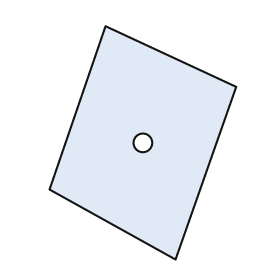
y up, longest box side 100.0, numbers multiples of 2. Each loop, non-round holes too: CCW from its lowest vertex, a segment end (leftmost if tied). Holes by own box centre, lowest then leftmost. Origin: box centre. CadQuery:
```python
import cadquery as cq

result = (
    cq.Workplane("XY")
    .moveTo(14.0, -50.0)
    .lineTo(40.0, 24.0)
    .lineTo(-16.0, 50.0)
    .lineTo(-40.0, -20.0)
    .close()
    .moveTo(0.0, 0.0)
    .circle(4.0)
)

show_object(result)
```